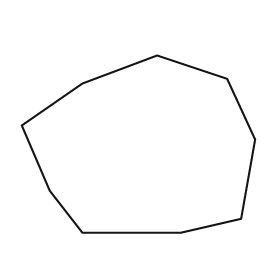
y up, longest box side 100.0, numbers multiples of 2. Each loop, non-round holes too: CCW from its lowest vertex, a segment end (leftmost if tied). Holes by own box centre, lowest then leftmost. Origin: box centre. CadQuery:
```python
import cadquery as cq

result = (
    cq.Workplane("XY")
    .moveTo(-24.0, -38.0)
    .lineTo(18.0, -38.0)
    .lineTo(44.0, -32.0)
    .lineTo(50.0, 2.0)
    .lineTo(38.0, 28.0)
    .lineTo(8.0, 38.0)
    .lineTo(-24.0, 26.0)
    .lineTo(-50.0, 8.0)
    .lineTo(-38.0, -20.0)
    .close()
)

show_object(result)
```